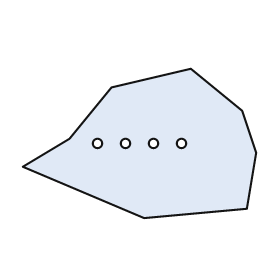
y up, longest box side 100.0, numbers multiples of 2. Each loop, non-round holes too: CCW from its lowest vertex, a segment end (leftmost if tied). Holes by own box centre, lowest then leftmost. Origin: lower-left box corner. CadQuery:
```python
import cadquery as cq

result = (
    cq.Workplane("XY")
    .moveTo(52.0, 0.0)
    .lineTo(96.0, 4.0)
    .lineTo(100.0, 28.0)
    .lineTo(94.0, 46.0)
    .lineTo(72.0, 64.0)
    .lineTo(38.0, 56.0)
    .lineTo(20.0, 34.0)
    .lineTo(0.0, 22.0)
    .close()
    .moveTo(32.0, 32.0)
    .circle(2.0)
    .moveTo(44.0, 32.0)
    .circle(2.0)
    .moveTo(56.0, 32.0)
    .circle(2.0)
    .moveTo(68.0, 32.0)
    .circle(2.0)
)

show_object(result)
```